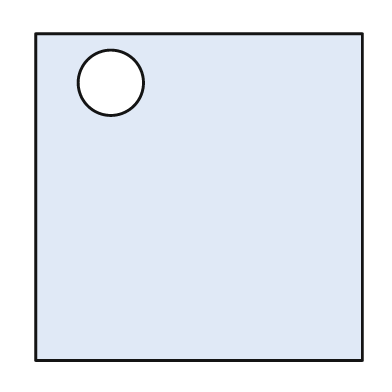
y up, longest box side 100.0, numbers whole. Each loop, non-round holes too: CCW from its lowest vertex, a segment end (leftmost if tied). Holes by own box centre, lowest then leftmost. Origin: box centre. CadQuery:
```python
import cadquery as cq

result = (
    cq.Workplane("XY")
    .moveTo(-50.0, -50.0)
    .lineTo(50.0, -50.0)
    .lineTo(50.0, 50.0)
    .lineTo(-50.0, 50.0)
    .close()
    .moveTo(-27.0, 35.0)
    .circle(10.0)
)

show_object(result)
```